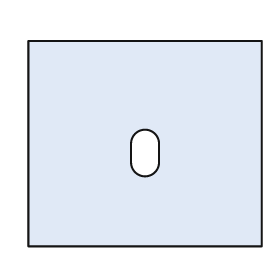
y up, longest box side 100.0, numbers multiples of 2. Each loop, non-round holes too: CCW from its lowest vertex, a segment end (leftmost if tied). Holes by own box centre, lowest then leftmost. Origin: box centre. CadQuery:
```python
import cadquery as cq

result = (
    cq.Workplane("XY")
    .moveTo(-50.0, -44.0)
    .lineTo(50.0, -44.0)
    .lineTo(50.0, 44.0)
    .lineTo(-50.0, 44.0)
    .close()
    .moveTo(-6.0, -8.0)
    .threePointArc((0.0, -14.0), (6.0, -8.0))
    .lineTo(6.0, 0.0)
    .threePointArc((0.0, 6.0), (-6.0, 0.0))
    .close()
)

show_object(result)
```